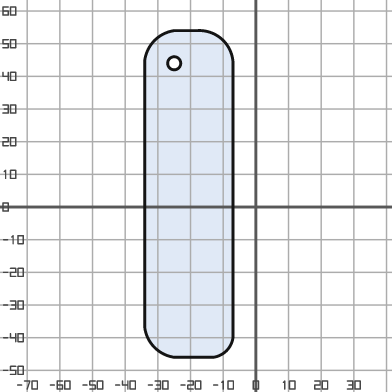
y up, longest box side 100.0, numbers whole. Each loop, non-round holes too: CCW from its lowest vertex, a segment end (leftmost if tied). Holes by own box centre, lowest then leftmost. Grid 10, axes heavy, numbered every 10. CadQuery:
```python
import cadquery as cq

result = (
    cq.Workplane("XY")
    .moveTo(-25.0, -46.0)
    .lineTo(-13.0, -46.0)
    .threePointArc((-9.0, -44.0), (-7.0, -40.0))
    .lineTo(-7.0, 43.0)
    .threePointArc((-10.0, 51.0), (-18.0, 54.0))
    .lineTo(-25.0, 54.0)
    .threePointArc((-31.0, 51.0), (-34.0, 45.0))
    .lineTo(-34.0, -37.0)
    .threePointArc((-31.0, -43.0), (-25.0, -46.0))
    .close()
    .moveTo(-25.0, 44.0)
    .circle(2.0)
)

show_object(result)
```